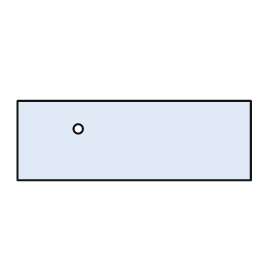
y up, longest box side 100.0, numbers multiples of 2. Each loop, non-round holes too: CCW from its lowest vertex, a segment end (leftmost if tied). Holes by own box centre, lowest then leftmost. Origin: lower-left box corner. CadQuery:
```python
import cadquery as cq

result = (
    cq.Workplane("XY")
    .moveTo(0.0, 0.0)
    .lineTo(100.0, 0.0)
    .lineTo(100.0, 34.0)
    .lineTo(0.0, 34.0)
    .close()
    .moveTo(26.0, 22.0)
    .circle(2.0)
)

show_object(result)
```